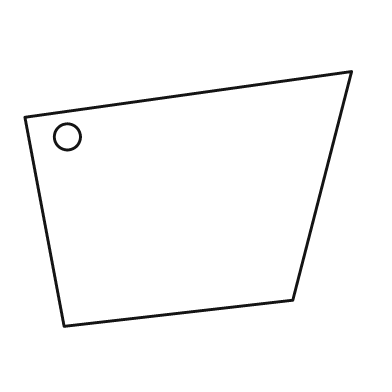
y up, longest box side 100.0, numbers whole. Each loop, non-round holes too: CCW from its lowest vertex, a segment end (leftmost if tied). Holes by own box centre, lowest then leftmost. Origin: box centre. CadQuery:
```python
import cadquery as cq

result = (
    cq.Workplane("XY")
    .moveTo(-38.0, -39.0)
    .lineTo(32.0, -31.0)
    .lineTo(50.0, 39.0)
    .lineTo(-50.0, 25.0)
    .close()
    .moveTo(-37.0, 19.0)
    .circle(4.0)
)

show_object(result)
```